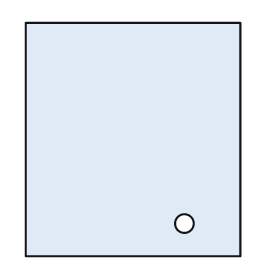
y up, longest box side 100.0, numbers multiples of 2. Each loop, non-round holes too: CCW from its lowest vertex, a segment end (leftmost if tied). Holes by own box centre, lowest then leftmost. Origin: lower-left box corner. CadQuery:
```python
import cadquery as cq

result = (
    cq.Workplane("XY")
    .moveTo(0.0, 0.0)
    .lineTo(92.0, 0.0)
    .lineTo(92.0, 100.0)
    .lineTo(0.0, 100.0)
    .close()
    .moveTo(68.0, 14.0)
    .circle(4.0)
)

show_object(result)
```